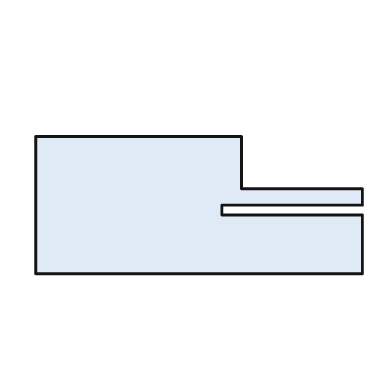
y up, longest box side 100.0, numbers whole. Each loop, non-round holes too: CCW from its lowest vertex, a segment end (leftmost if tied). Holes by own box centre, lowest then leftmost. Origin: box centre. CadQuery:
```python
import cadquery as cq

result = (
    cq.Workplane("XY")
    .moveTo(-50.0, -21.0)
    .lineTo(50.0, -21.0)
    .lineTo(50.0, -3.0)
    .lineTo(7.0, -3.0)
    .lineTo(7.0, 0.0)
    .lineTo(50.0, 0.0)
    .lineTo(50.0, 5.0)
    .lineTo(13.0, 5.0)
    .lineTo(13.0, 21.0)
    .lineTo(-50.0, 21.0)
    .close()
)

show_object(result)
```